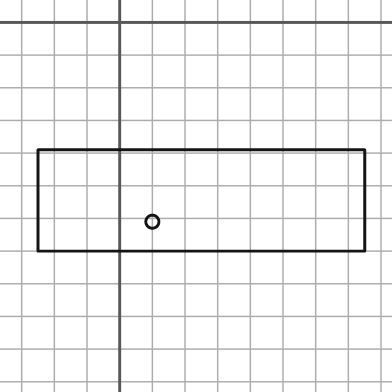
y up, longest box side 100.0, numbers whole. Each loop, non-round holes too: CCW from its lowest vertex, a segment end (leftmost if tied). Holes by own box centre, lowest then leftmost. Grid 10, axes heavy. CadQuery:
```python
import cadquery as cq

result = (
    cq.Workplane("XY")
    .moveTo(-25.0, -70.0)
    .lineTo(75.0, -70.0)
    .lineTo(75.0, -39.0)
    .lineTo(-25.0, -39.0)
    .close()
    .moveTo(10.0, -61.0)
    .circle(2.0)
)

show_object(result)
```